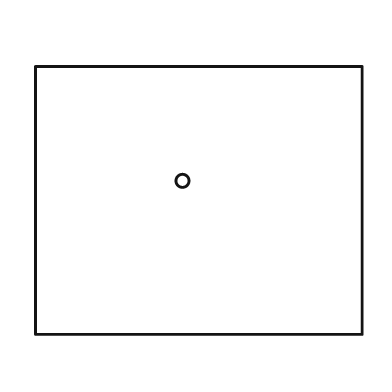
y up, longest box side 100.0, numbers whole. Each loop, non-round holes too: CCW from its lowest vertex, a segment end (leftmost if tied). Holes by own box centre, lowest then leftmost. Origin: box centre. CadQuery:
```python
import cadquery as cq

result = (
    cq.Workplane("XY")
    .moveTo(-50.0, -41.0)
    .lineTo(50.0, -41.0)
    .lineTo(50.0, 41.0)
    .lineTo(-50.0, 41.0)
    .close()
    .moveTo(-5.0, 6.0)
    .circle(2.0)
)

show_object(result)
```